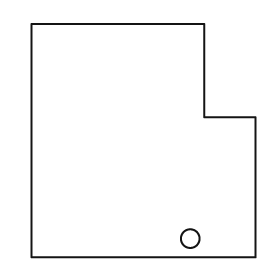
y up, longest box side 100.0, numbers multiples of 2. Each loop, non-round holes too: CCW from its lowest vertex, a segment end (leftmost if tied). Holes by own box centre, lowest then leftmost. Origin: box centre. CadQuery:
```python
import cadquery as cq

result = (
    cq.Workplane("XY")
    .moveTo(-48.0, -50.0)
    .lineTo(48.0, -50.0)
    .lineTo(48.0, 10.0)
    .lineTo(26.0, 10.0)
    .lineTo(26.0, 50.0)
    .lineTo(-48.0, 50.0)
    .close()
    .moveTo(20.0, -42.0)
    .circle(4.0)
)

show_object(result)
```